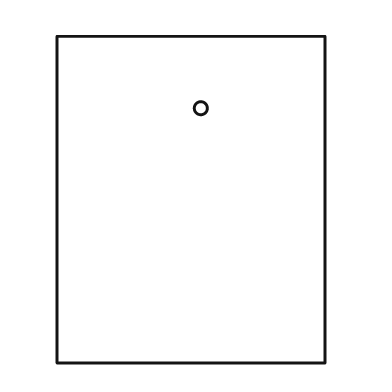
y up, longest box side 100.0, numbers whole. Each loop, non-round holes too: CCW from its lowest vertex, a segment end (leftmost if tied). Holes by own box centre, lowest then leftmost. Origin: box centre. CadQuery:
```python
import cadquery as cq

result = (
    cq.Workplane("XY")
    .moveTo(-41.0, -50.0)
    .lineTo(41.0, -50.0)
    .lineTo(41.0, 50.0)
    .lineTo(-41.0, 50.0)
    .close()
    .moveTo(3.0, 28.0)
    .circle(2.0)
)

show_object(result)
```